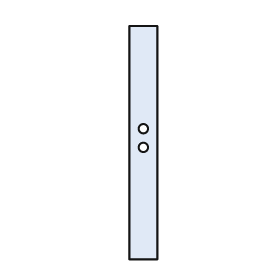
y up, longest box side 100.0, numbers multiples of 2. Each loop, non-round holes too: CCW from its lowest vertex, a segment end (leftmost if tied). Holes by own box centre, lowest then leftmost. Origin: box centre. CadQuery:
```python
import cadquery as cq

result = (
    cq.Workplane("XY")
    .moveTo(-6.0, -50.0)
    .lineTo(6.0, -50.0)
    .lineTo(6.0, 50.0)
    .lineTo(-6.0, 50.0)
    .close()
    .moveTo(0.0, -2.0)
    .circle(2.0)
    .moveTo(0.0, 6.0)
    .circle(2.0)
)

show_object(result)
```